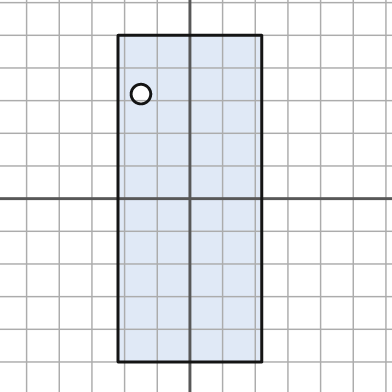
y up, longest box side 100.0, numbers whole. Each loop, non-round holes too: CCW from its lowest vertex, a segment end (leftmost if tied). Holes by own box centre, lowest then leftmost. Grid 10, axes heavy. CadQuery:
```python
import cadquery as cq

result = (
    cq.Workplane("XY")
    .moveTo(-22.0, -50.0)
    .lineTo(22.0, -50.0)
    .lineTo(22.0, 50.0)
    .lineTo(-22.0, 50.0)
    .close()
    .moveTo(-15.0, 32.0)
    .circle(3.0)
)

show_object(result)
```